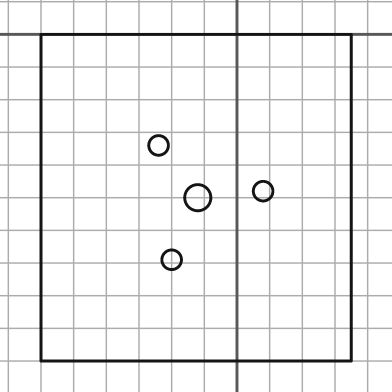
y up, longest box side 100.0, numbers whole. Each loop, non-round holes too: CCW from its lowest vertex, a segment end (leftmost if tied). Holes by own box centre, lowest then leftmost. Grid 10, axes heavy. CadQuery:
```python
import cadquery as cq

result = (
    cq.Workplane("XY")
    .moveTo(-60.0, -100.0)
    .lineTo(35.0, -100.0)
    .lineTo(35.0, 0.0)
    .lineTo(-60.0, 0.0)
    .close()
    .moveTo(-20.0, -69.0)
    .circle(3.0)
    .moveTo(-12.0, -50.0)
    .circle(4.0)
    .moveTo(8.0, -48.0)
    .circle(3.0)
    .moveTo(-24.0, -34.0)
    .circle(3.0)
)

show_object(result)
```